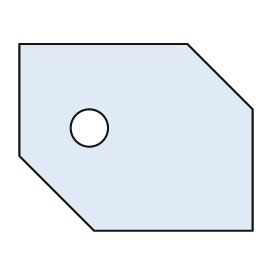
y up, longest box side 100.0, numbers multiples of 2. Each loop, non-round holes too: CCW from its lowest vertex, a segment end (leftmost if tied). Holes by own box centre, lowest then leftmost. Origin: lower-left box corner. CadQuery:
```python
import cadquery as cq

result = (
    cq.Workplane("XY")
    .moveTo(32.0, 0.0)
    .lineTo(100.0, 0.0)
    .lineTo(100.0, 52.0)
    .lineTo(72.0, 80.0)
    .lineTo(0.0, 80.0)
    .lineTo(0.0, 32.0)
    .close()
    .moveTo(30.0, 44.0)
    .circle(8.0)
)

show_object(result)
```